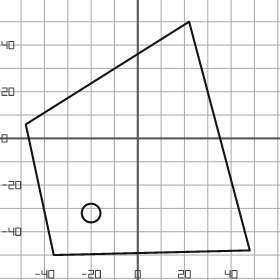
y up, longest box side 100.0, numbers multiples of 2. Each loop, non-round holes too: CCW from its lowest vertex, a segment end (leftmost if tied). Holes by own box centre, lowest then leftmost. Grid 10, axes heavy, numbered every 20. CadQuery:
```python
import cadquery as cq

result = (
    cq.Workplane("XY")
    .moveTo(-36.0, -50.0)
    .lineTo(48.0, -48.0)
    .lineTo(22.0, 50.0)
    .lineTo(-48.0, 6.0)
    .close()
    .moveTo(-20.0, -32.0)
    .circle(4.0)
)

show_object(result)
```